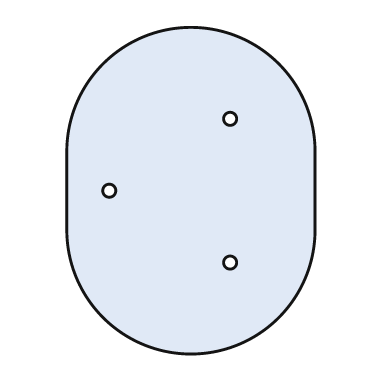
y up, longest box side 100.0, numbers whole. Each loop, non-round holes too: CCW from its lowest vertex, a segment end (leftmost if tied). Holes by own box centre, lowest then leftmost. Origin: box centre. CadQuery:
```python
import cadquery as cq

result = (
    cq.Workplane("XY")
    .moveTo(-38.0, -12.0)
    .threePointArc((0.0, -50.0), (38.0, -12.0))
    .lineTo(38.0, 12.0)
    .threePointArc((0.0, 50.0), (-38.0, 12.0))
    .close()
    .moveTo(12.0, -22.0)
    .circle(2.0)
    .moveTo(-25.0, 0.0)
    .circle(2.0)
    .moveTo(12.0, 22.0)
    .circle(2.0)
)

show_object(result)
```